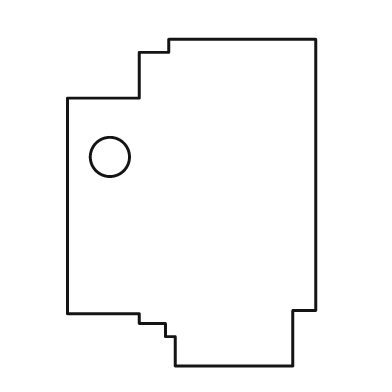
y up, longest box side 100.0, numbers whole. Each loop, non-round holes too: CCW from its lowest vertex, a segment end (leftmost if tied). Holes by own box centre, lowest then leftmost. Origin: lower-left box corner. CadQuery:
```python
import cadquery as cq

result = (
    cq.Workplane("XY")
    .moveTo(33.0, 0.0)
    .lineTo(69.0, 0.0)
    .lineTo(69.0, 17.0)
    .lineTo(76.0, 17.0)
    .lineTo(76.0, 100.0)
    .lineTo(31.0, 100.0)
    .lineTo(31.0, 96.0)
    .lineTo(22.0, 96.0)
    .lineTo(22.0, 82.0)
    .lineTo(0.0, 82.0)
    .lineTo(0.0, 16.0)
    .lineTo(22.0, 16.0)
    .lineTo(22.0, 13.0)
    .lineTo(30.0, 13.0)
    .lineTo(30.0, 9.0)
    .lineTo(33.0, 9.0)
    .close()
    .moveTo(13.0, 64.0)
    .circle(6.0)
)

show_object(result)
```